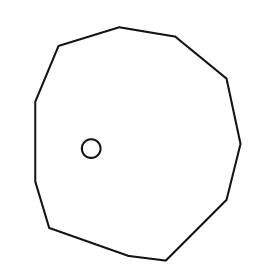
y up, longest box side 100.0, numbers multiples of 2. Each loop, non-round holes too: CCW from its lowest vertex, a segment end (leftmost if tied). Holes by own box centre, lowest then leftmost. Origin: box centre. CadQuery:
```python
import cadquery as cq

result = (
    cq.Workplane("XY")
    .moveTo(12.0, -50.0)
    .lineTo(38.0, -24.0)
    .lineTo(44.0, 0.0)
    .lineTo(38.0, 28.0)
    .lineTo(16.0, 46.0)
    .lineTo(-8.0, 50.0)
    .lineTo(-34.0, 42.0)
    .lineTo(-44.0, 18.0)
    .lineTo(-44.0, -16.0)
    .lineTo(-38.0, -36.0)
    .lineTo(-4.0, -48.0)
    .close()
    .moveTo(-20.0, -2.0)
    .circle(4.0)
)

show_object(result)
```